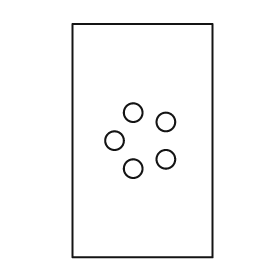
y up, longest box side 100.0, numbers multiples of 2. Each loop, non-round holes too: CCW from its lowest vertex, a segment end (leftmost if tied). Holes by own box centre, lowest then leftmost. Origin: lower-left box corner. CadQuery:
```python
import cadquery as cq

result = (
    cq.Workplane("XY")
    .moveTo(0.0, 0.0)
    .lineTo(60.0, 0.0)
    .lineTo(60.0, 100.0)
    .lineTo(0.0, 100.0)
    .close()
    .moveTo(26.0, 38.0)
    .circle(4.0)
    .moveTo(40.0, 42.0)
    .circle(4.0)
    .moveTo(18.0, 50.0)
    .circle(4.0)
    .moveTo(40.0, 58.0)
    .circle(4.0)
    .moveTo(26.0, 62.0)
    .circle(4.0)
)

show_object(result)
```